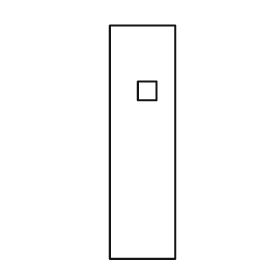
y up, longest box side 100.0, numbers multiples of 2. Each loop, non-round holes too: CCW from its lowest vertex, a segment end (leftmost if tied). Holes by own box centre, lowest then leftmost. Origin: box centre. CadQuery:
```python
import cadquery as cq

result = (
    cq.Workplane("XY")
    .moveTo(-14.0, -50.0)
    .lineTo(14.0, -50.0)
    .lineTo(14.0, 50.0)
    .lineTo(-14.0, 50.0)
    .close()
    .moveTo(-2.0, 18.0)
    .lineTo(6.0, 18.0)
    .lineTo(6.0, 26.0)
    .lineTo(-2.0, 26.0)
    .close()
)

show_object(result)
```